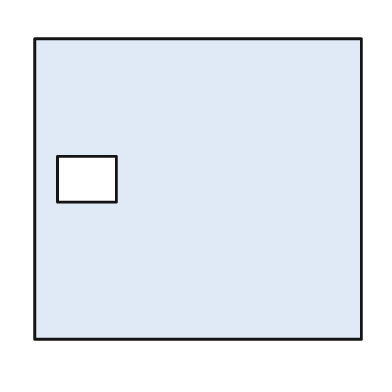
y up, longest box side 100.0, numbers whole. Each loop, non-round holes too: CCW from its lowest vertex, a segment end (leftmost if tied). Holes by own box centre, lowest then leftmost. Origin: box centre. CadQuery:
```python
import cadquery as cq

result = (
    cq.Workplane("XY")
    .moveTo(-50.0, -46.0)
    .lineTo(50.0, -46.0)
    .lineTo(50.0, 46.0)
    .lineTo(-50.0, 46.0)
    .close()
    .moveTo(-43.0, -4.0)
    .lineTo(-25.0, -4.0)
    .lineTo(-25.0, 10.0)
    .lineTo(-43.0, 10.0)
    .close()
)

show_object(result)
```